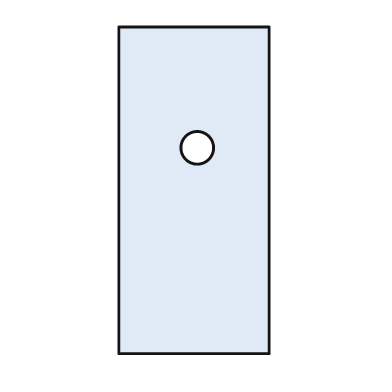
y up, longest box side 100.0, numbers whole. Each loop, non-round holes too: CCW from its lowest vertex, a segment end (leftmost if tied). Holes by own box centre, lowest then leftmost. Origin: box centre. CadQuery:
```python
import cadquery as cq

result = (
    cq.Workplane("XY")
    .moveTo(-23.0, -50.0)
    .lineTo(23.0, -50.0)
    .lineTo(23.0, 50.0)
    .lineTo(-23.0, 50.0)
    .close()
    .moveTo(1.0, 13.0)
    .circle(5.0)
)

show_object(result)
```